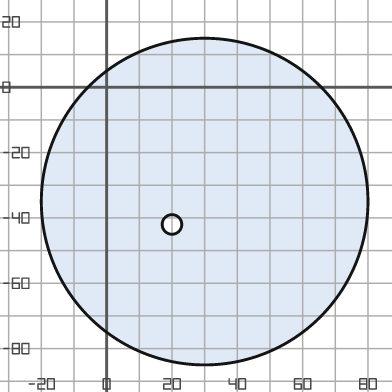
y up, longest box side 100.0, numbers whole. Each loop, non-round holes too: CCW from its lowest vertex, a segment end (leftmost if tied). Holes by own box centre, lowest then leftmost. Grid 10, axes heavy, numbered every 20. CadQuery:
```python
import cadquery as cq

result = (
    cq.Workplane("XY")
    .moveTo(30.0, -35.0)
    .circle(50.0)
    .moveTo(20.0, -42.0)
    .circle(3.0)
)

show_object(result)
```